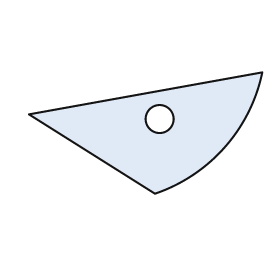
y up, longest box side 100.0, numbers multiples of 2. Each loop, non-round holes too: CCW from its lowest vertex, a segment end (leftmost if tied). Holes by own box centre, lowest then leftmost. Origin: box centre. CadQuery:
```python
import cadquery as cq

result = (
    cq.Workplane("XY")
    .moveTo(4.0, -26.0)
    .threePointArc((34.0, -6.0), (50.0, 26.0))
    .lineTo(-50.0, 8.0)
    .close()
    .moveTo(6.0, 6.0)
    .circle(6.0)
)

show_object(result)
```